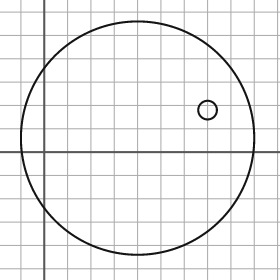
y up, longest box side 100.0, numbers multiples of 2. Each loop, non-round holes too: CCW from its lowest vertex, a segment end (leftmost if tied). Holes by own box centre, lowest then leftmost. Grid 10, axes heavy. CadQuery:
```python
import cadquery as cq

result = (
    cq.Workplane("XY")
    .moveTo(40.0, 6.0)
    .circle(50.0)
    .moveTo(70.0, 18.0)
    .circle(4.0)
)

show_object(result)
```